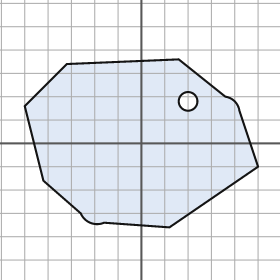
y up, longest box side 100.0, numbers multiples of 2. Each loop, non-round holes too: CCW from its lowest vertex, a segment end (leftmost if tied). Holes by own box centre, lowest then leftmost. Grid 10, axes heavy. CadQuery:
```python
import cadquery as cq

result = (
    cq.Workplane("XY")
    .moveTo(12.0, -36.0)
    .lineTo(50.0, -10.0)
    .lineTo(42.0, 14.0)
    .threePointArc((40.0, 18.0), (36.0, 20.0))
    .lineTo(16.0, 36.0)
    .lineTo(-32.0, 34.0)
    .lineTo(-50.0, 16.0)
    .lineTo(-42.0, -16.0)
    .lineTo(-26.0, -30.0)
    .threePointArc((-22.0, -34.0), (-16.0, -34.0))
    .close()
    .moveTo(20.0, 18.0)
    .circle(4.0)
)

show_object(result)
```